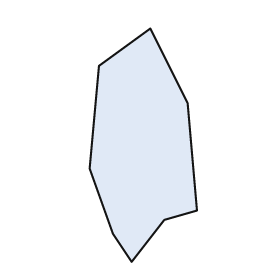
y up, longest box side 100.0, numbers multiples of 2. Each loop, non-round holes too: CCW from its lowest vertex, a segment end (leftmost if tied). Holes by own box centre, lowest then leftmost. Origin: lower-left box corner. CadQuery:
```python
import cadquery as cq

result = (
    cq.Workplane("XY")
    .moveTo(18.0, 0.0)
    .lineTo(32.0, 18.0)
    .lineTo(46.0, 22.0)
    .lineTo(42.0, 68.0)
    .lineTo(26.0, 100.0)
    .lineTo(4.0, 84.0)
    .lineTo(0.0, 40.0)
    .lineTo(10.0, 12.0)
    .close()
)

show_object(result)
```